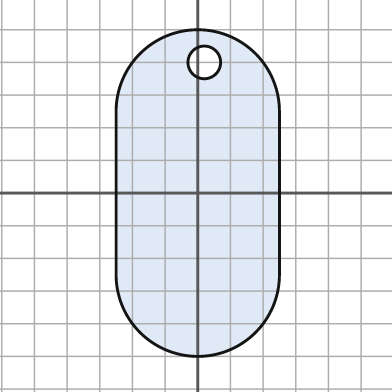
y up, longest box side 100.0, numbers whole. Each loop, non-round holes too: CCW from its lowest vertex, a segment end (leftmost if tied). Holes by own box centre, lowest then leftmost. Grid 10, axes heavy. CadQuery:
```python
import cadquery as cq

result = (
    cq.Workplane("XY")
    .moveTo(-25.0, -25.0)
    .threePointArc((0.0, -50.0), (25.0, -25.0))
    .lineTo(25.0, 25.0)
    .threePointArc((0.0, 50.0), (-25.0, 25.0))
    .close()
    .moveTo(2.0, 40.0)
    .circle(5.0)
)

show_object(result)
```